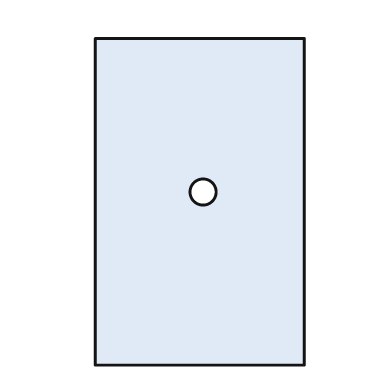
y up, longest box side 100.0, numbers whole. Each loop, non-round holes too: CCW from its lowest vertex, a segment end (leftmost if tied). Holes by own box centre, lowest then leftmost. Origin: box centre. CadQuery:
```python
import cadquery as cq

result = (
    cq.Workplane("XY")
    .moveTo(-32.0, -50.0)
    .lineTo(32.0, -50.0)
    .lineTo(32.0, 50.0)
    .lineTo(-32.0, 50.0)
    .close()
    .moveTo(1.0, 3.0)
    .circle(4.0)
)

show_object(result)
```